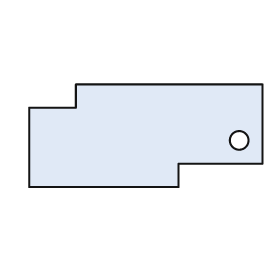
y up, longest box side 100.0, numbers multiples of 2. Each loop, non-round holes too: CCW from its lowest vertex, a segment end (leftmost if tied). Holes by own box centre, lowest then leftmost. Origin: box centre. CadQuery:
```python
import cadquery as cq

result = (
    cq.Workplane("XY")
    .moveTo(-50.0, -22.0)
    .lineTo(14.0, -22.0)
    .lineTo(14.0, -12.0)
    .lineTo(50.0, -12.0)
    .lineTo(50.0, 22.0)
    .lineTo(-30.0, 22.0)
    .lineTo(-30.0, 12.0)
    .lineTo(-50.0, 12.0)
    .close()
    .moveTo(40.0, -2.0)
    .circle(4.0)
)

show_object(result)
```